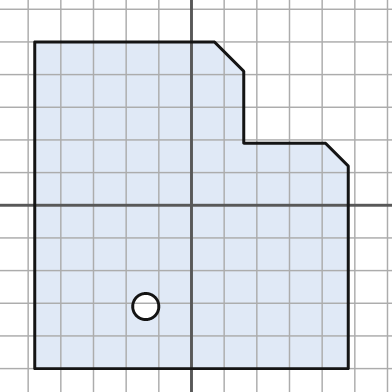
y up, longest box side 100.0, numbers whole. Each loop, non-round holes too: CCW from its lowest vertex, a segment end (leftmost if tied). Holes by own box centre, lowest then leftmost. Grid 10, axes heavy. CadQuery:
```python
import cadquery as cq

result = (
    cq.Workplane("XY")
    .moveTo(-48.0, -50.0)
    .lineTo(48.0, -50.0)
    .lineTo(48.0, 12.0)
    .lineTo(41.0, 19.0)
    .lineTo(16.0, 19.0)
    .lineTo(16.0, 41.0)
    .lineTo(7.0, 50.0)
    .lineTo(-48.0, 50.0)
    .close()
    .moveTo(-14.0, -31.0)
    .circle(4.0)
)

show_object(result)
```